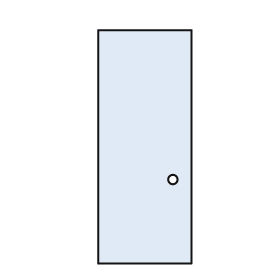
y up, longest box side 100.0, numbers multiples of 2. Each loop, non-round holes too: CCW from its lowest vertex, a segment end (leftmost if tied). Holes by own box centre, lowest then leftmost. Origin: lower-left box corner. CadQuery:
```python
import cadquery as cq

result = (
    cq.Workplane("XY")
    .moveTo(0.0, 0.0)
    .lineTo(40.0, 0.0)
    .lineTo(40.0, 100.0)
    .lineTo(0.0, 100.0)
    .close()
    .moveTo(32.0, 36.0)
    .circle(2.0)
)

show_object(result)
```